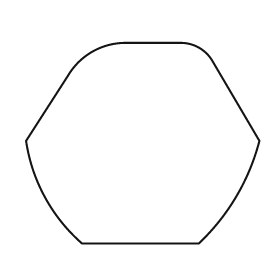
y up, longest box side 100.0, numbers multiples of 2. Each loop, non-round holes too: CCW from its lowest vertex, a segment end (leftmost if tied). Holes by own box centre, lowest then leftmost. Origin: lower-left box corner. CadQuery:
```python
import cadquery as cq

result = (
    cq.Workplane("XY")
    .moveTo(24.0, 0.0)
    .lineTo(74.0, 0.0)
    .threePointArc((90.0, 20.0), (100.0, 44.0))
    .lineTo(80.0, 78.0)
    .threePointArc((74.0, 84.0), (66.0, 86.0))
    .lineTo(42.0, 86.0)
    .threePointArc((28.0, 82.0), (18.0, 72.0))
    .lineTo(0.0, 44.0)
    .threePointArc((8.0, 20.0), (24.0, 0.0))
    .close()
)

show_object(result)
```